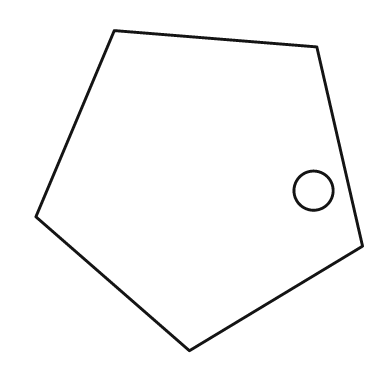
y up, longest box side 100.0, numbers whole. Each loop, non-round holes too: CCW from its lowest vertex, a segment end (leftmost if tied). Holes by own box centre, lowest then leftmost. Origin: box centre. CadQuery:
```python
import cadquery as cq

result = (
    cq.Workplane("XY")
    .moveTo(-3.0, -49.0)
    .lineTo(50.0, -17.0)
    .lineTo(36.0, 44.0)
    .lineTo(-26.0, 49.0)
    .lineTo(-50.0, -8.0)
    .close()
    .moveTo(35.0, 0.0)
    .circle(6.0)
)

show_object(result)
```